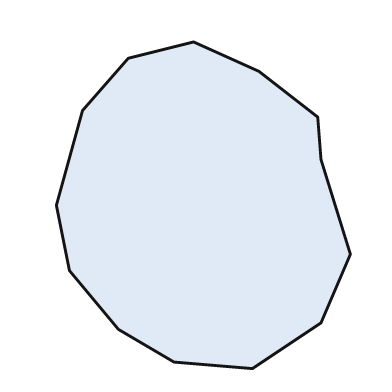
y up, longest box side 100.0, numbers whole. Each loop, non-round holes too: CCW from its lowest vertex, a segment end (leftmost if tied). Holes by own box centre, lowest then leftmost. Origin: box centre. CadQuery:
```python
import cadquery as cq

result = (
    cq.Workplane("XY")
    .moveTo(15.0, -50.0)
    .lineTo(36.0, -36.0)
    .lineTo(45.0, -15.0)
    .lineTo(36.0, 14.0)
    .lineTo(35.0, 27.0)
    .lineTo(17.0, 41.0)
    .lineTo(-3.0, 50.0)
    .lineTo(-23.0, 45.0)
    .lineTo(-37.0, 29.0)
    .lineTo(-45.0, 0.0)
    .lineTo(-41.0, -20.0)
    .lineTo(-26.0, -38.0)
    .lineTo(-9.0, -48.0)
    .close()
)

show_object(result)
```